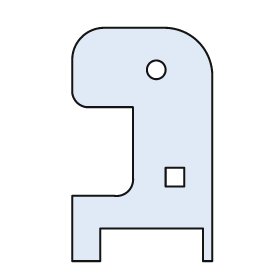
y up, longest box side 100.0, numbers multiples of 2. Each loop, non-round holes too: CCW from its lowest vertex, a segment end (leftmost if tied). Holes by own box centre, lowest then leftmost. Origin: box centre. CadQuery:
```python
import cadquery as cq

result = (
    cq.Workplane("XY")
    .moveTo(-30.0, -50.0)
    .lineTo(-18.0, -50.0)
    .lineTo(-18.0, -36.0)
    .lineTo(26.0, -36.0)
    .lineTo(26.0, -50.0)
    .lineTo(30.0, -50.0)
    .lineTo(30.0, 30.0)
    .threePointArc((24.0, 44.0), (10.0, 50.0))
    .lineTo(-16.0, 50.0)
    .threePointArc((-26.0, 46.0), (-30.0, 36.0))
    .lineTo(-30.0, 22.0)
    .threePointArc((-28.0, 18.0), (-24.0, 16.0))
    .lineTo(-4.0, 16.0)
    .lineTo(-4.0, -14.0)
    .threePointArc((-6.0, -20.0), (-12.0, -22.0))
    .lineTo(-30.0, -22.0)
    .close()
    .moveTo(10.0, -18.0)
    .lineTo(18.0, -18.0)
    .lineTo(18.0, -10.0)
    .lineTo(10.0, -10.0)
    .close()
    .moveTo(6.0, 32.0)
    .circle(4.0)
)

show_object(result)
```